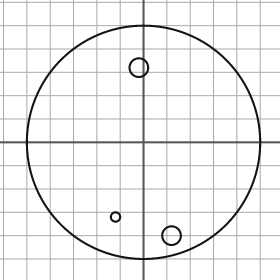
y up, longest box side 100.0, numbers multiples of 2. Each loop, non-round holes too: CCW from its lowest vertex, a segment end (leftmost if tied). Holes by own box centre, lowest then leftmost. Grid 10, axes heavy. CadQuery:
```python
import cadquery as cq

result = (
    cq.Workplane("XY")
    .moveTo(0.0, 0.0)
    .circle(50.0)
    .moveTo(12.0, -40.0)
    .circle(4.0)
    .moveTo(-12.0, -32.0)
    .circle(2.0)
    .moveTo(-2.0, 32.0)
    .circle(4.0)
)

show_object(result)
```